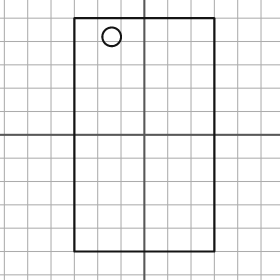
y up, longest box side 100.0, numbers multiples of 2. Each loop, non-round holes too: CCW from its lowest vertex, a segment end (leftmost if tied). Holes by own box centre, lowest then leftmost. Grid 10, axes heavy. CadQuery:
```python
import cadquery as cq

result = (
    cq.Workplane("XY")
    .moveTo(-30.0, -50.0)
    .lineTo(30.0, -50.0)
    .lineTo(30.0, 50.0)
    .lineTo(-30.0, 50.0)
    .close()
    .moveTo(-14.0, 42.0)
    .circle(4.0)
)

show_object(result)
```